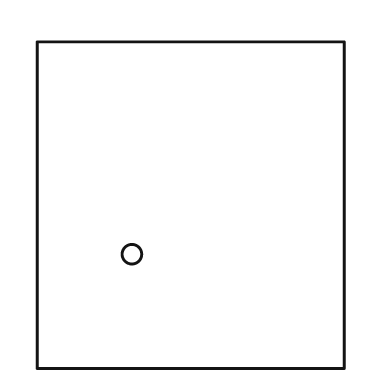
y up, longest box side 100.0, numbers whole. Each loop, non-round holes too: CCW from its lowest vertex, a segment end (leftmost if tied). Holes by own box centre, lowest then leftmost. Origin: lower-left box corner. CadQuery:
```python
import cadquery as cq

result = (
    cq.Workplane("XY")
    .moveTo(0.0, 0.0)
    .lineTo(94.0, 0.0)
    .lineTo(94.0, 100.0)
    .lineTo(0.0, 100.0)
    .close()
    .moveTo(29.0, 35.0)
    .circle(3.0)
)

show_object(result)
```